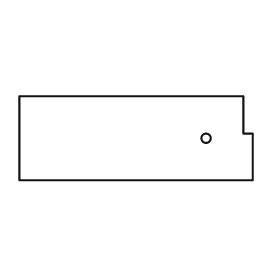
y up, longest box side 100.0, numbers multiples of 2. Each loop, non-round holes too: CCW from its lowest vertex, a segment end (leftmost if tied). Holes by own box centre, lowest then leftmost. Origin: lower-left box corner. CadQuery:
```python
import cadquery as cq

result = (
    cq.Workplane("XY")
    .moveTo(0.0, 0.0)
    .lineTo(100.0, 0.0)
    .lineTo(100.0, 20.0)
    .lineTo(96.0, 20.0)
    .lineTo(96.0, 36.0)
    .lineTo(0.0, 36.0)
    .close()
    .moveTo(80.0, 18.0)
    .circle(2.0)
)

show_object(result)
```